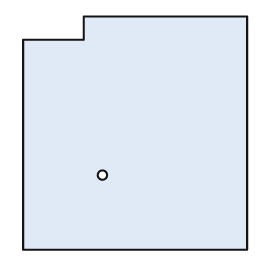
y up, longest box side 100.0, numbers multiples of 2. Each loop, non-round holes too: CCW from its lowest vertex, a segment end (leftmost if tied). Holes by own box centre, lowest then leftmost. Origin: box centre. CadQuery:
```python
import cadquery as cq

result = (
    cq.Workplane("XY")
    .moveTo(-48.0, -50.0)
    .lineTo(48.0, -50.0)
    .lineTo(48.0, 50.0)
    .lineTo(-22.0, 50.0)
    .lineTo(-22.0, 40.0)
    .lineTo(-48.0, 40.0)
    .close()
    .moveTo(-14.0, -18.0)
    .circle(2.0)
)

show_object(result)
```